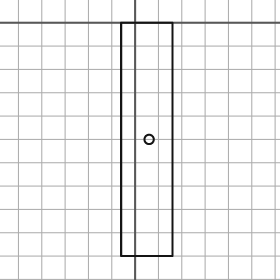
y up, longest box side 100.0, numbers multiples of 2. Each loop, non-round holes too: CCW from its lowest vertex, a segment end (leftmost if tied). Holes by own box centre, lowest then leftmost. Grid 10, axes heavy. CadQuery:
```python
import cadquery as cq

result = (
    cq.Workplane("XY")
    .moveTo(-6.0, -100.0)
    .lineTo(16.0, -100.0)
    .lineTo(16.0, 0.0)
    .lineTo(-6.0, 0.0)
    .close()
    .moveTo(6.0, -50.0)
    .circle(2.0)
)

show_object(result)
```